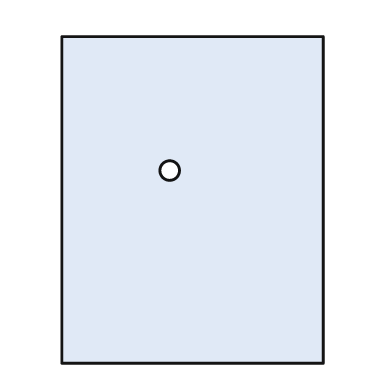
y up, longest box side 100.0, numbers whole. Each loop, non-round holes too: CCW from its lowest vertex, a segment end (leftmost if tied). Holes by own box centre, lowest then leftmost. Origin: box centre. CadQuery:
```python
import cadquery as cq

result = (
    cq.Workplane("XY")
    .moveTo(-40.0, -50.0)
    .lineTo(40.0, -50.0)
    .lineTo(40.0, 50.0)
    .lineTo(-40.0, 50.0)
    .close()
    .moveTo(-7.0, 9.0)
    .circle(3.0)
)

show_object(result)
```